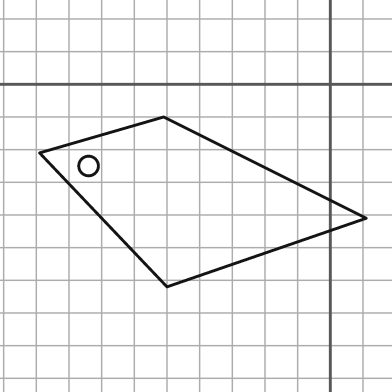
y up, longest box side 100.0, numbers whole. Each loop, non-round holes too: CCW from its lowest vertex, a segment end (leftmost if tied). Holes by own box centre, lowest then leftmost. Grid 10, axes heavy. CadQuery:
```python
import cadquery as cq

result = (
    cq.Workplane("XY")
    .moveTo(-50.0, -62.0)
    .lineTo(11.0, -41.0)
    .lineTo(-51.0, -10.0)
    .lineTo(-89.0, -21.0)
    .close()
    .moveTo(-74.0, -25.0)
    .circle(3.0)
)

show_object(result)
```